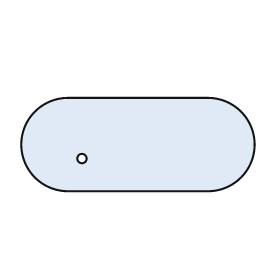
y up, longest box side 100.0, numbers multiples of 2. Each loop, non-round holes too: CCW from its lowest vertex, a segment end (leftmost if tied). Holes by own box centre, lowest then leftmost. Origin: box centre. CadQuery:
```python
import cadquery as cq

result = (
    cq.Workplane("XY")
    .moveTo(-30.0, -20.0)
    .lineTo(30.0, -20.0)
    .threePointArc((50.0, 0.0), (30.0, 20.0))
    .lineTo(-30.0, 20.0)
    .threePointArc((-50.0, 0.0), (-30.0, -20.0))
    .close()
    .moveTo(-24.0, -6.0)
    .circle(2.0)
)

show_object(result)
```